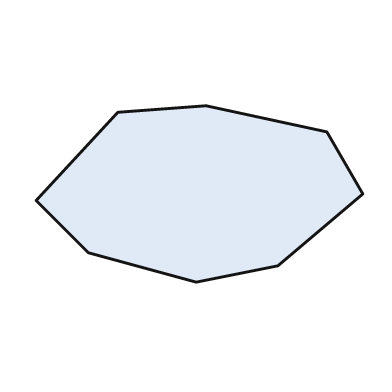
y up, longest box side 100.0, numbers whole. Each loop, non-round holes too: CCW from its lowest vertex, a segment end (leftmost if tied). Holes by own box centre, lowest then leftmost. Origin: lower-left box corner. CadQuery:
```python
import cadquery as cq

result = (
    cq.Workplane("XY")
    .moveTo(49.0, 0.0)
    .lineTo(74.0, 5.0)
    .lineTo(100.0, 27.0)
    .lineTo(89.0, 46.0)
    .lineTo(52.0, 54.0)
    .lineTo(25.0, 52.0)
    .lineTo(0.0, 25.0)
    .lineTo(16.0, 9.0)
    .close()
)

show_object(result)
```